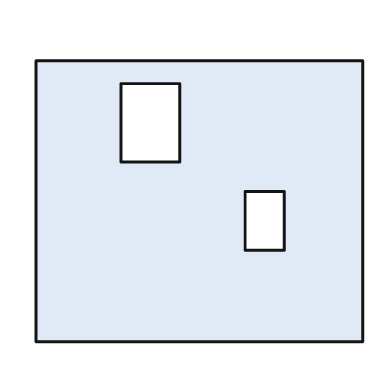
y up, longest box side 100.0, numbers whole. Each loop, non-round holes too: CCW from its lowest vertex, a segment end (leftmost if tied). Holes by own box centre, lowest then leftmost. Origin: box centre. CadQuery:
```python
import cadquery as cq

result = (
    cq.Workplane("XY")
    .moveTo(-50.0, -43.0)
    .lineTo(50.0, -43.0)
    .lineTo(50.0, 43.0)
    .lineTo(-50.0, 43.0)
    .close()
    .moveTo(14.0, -15.0)
    .lineTo(26.0, -15.0)
    .lineTo(26.0, 3.0)
    .lineTo(14.0, 3.0)
    .close()
    .moveTo(-24.0, 12.0)
    .lineTo(-6.0, 12.0)
    .lineTo(-6.0, 36.0)
    .lineTo(-24.0, 36.0)
    .close()
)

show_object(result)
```